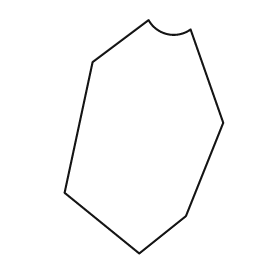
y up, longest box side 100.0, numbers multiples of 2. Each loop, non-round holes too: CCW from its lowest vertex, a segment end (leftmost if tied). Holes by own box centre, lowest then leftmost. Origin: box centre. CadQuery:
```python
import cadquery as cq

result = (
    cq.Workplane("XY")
    .moveTo(-2.0, -50.0)
    .lineTo(18.0, -34.0)
    .lineTo(34.0, 6.0)
    .lineTo(20.0, 46.0)
    .threePointArc((10.0, 44.0), (2.0, 50.0))
    .lineTo(-22.0, 32.0)
    .lineTo(-34.0, -24.0)
    .close()
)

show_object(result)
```